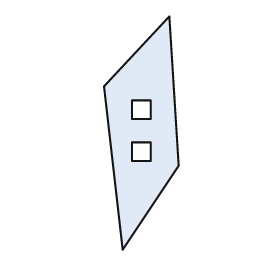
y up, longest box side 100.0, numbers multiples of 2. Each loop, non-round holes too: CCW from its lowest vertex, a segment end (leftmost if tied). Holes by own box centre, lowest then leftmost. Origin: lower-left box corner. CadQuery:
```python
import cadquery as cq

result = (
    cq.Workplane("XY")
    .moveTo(8.0, 0.0)
    .lineTo(32.0, 36.0)
    .lineTo(28.0, 100.0)
    .lineTo(0.0, 70.0)
    .close()
    .moveTo(12.0, 38.0)
    .lineTo(20.0, 38.0)
    .lineTo(20.0, 46.0)
    .lineTo(12.0, 46.0)
    .close()
    .moveTo(12.0, 56.0)
    .lineTo(20.0, 56.0)
    .lineTo(20.0, 64.0)
    .lineTo(12.0, 64.0)
    .close()
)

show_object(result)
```